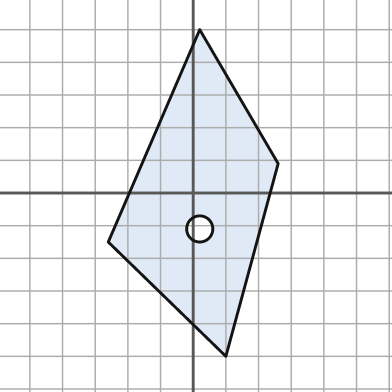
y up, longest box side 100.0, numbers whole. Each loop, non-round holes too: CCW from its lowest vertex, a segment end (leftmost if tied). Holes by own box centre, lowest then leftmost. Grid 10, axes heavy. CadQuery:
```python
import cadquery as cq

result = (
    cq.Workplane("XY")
    .moveTo(10.0, -50.0)
    .lineTo(26.0, 9.0)
    .lineTo(2.0, 50.0)
    .lineTo(-26.0, -15.0)
    .close()
    .moveTo(2.0, -11.0)
    .circle(4.0)
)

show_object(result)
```